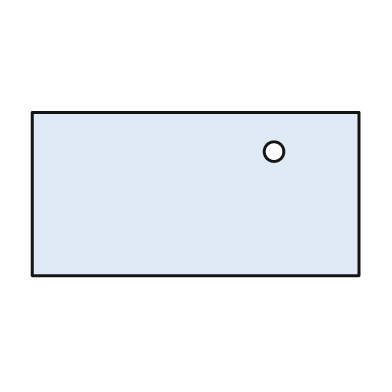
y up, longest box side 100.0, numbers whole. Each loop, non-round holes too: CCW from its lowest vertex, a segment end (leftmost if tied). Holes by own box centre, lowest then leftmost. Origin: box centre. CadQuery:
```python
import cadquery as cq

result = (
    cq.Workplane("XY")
    .moveTo(-50.0, -25.0)
    .lineTo(50.0, -25.0)
    .lineTo(50.0, 25.0)
    .lineTo(-50.0, 25.0)
    .close()
    .moveTo(24.0, 13.0)
    .circle(3.0)
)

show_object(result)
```